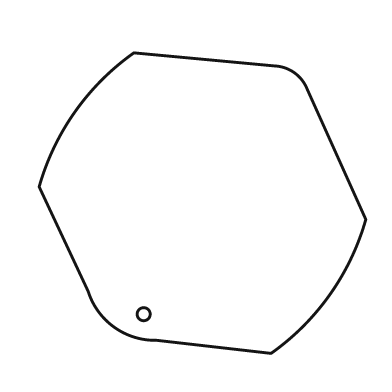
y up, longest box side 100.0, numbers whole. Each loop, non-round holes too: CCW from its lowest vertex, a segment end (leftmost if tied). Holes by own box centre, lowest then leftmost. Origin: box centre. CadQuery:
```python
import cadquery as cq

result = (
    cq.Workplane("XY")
    .moveTo(21.0, -46.0)
    .threePointArc((39.0, -28.0), (50.0, -5.0))
    .lineTo(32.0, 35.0)
    .threePointArc((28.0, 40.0), (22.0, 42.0))
    .lineTo(-21.0, 46.0)
    .threePointArc((-39.0, 28.0), (-50.0, 5.0))
    .lineTo(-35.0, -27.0)
    .threePointArc((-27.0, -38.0), (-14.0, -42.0))
    .close()
    .moveTo(-18.0, -34.0)
    .circle(2.0)
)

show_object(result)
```